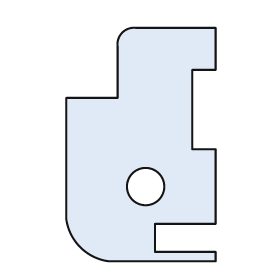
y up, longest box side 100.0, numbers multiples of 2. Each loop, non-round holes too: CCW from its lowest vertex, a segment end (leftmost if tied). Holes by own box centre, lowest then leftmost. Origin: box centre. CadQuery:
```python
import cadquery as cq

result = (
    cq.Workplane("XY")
    .moveTo(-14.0, -50.0)
    .lineTo(32.0, -50.0)
    .lineTo(32.0, -46.0)
    .lineTo(6.0, -46.0)
    .lineTo(6.0, -34.0)
    .lineTo(32.0, -34.0)
    .lineTo(32.0, -2.0)
    .lineTo(22.0, -2.0)
    .lineTo(22.0, 32.0)
    .lineTo(32.0, 32.0)
    .lineTo(32.0, 50.0)
    .lineTo(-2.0, 50.0)
    .threePointArc((-8.0, 48.0), (-10.0, 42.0))
    .lineTo(-10.0, 20.0)
    .lineTo(-32.0, 20.0)
    .lineTo(-32.0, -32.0)
    .threePointArc((-26.0, -44.0), (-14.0, -50.0))
    .close()
    .moveTo(2.0, -18.0)
    .circle(8.0)
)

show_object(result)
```